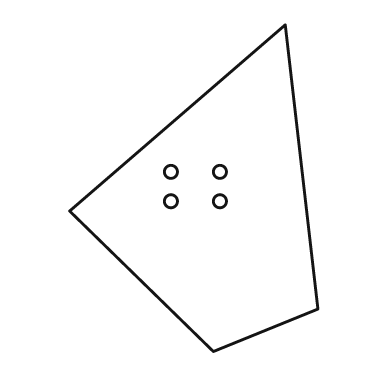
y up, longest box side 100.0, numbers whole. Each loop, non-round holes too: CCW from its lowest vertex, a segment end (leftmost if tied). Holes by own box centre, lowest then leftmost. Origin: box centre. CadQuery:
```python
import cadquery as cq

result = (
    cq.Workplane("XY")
    .moveTo(6.0, -50.0)
    .lineTo(38.0, -37.0)
    .lineTo(28.0, 50.0)
    .lineTo(-38.0, -7.0)
    .close()
    .moveTo(-7.0, -4.0)
    .circle(2.0)
    .moveTo(8.0, -4.0)
    .circle(2.0)
    .moveTo(-7.0, 5.0)
    .circle(2.0)
    .moveTo(8.0, 5.0)
    .circle(2.0)
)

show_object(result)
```